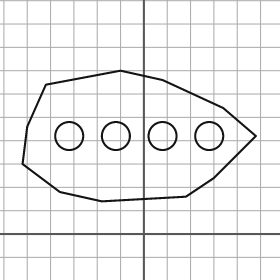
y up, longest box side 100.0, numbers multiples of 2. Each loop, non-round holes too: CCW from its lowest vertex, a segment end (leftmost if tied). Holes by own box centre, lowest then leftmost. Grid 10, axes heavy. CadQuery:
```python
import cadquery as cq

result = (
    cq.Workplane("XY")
    .moveTo(-18.0, 14.0)
    .lineTo(18.0, 16.0)
    .lineTo(30.0, 24.0)
    .lineTo(48.0, 42.0)
    .lineTo(34.0, 54.0)
    .lineTo(8.0, 66.0)
    .lineTo(-10.0, 70.0)
    .lineTo(-42.0, 64.0)
    .lineTo(-50.0, 46.0)
    .lineTo(-52.0, 30.0)
    .lineTo(-36.0, 18.0)
    .close()
    .moveTo(-32.0, 42.0)
    .circle(6.0)
    .moveTo(-12.0, 42.0)
    .circle(6.0)
    .moveTo(8.0, 42.0)
    .circle(6.0)
    .moveTo(28.0, 42.0)
    .circle(6.0)
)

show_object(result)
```